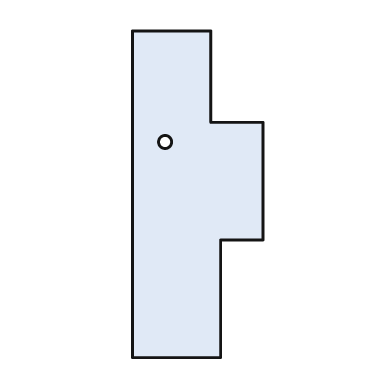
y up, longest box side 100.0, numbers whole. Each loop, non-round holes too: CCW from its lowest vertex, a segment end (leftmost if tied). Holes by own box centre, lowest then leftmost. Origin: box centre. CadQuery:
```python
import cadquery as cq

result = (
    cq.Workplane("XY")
    .moveTo(-20.0, -50.0)
    .lineTo(7.0, -50.0)
    .lineTo(7.0, -14.0)
    .lineTo(20.0, -14.0)
    .lineTo(20.0, 22.0)
    .lineTo(4.0, 22.0)
    .lineTo(4.0, 50.0)
    .lineTo(-20.0, 50.0)
    .close()
    .moveTo(-10.0, 16.0)
    .circle(2.0)
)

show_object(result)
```